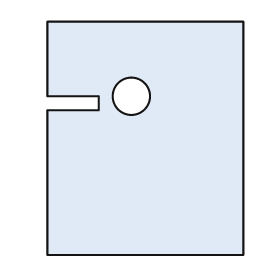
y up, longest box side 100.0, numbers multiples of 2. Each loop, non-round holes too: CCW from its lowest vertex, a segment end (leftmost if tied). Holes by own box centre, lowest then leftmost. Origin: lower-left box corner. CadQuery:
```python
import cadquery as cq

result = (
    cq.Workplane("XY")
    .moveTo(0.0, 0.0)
    .lineTo(84.0, 0.0)
    .lineTo(84.0, 100.0)
    .lineTo(0.0, 100.0)
    .lineTo(0.0, 68.0)
    .lineTo(22.0, 68.0)
    .lineTo(22.0, 62.0)
    .lineTo(0.0, 62.0)
    .close()
    .moveTo(36.0, 68.0)
    .circle(8.0)
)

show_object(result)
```